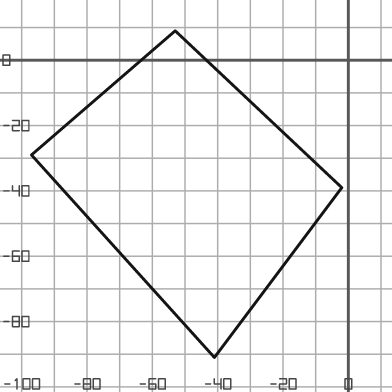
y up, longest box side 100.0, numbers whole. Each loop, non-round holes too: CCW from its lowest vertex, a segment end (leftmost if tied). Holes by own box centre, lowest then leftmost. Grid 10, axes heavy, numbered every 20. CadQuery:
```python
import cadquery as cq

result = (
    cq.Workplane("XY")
    .moveTo(-41.0, -91.0)
    .lineTo(-2.0, -39.0)
    .lineTo(-53.0, 9.0)
    .lineTo(-97.0, -29.0)
    .close()
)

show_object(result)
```